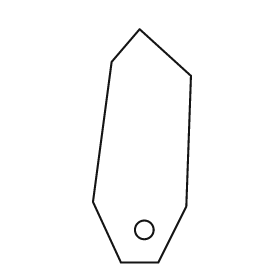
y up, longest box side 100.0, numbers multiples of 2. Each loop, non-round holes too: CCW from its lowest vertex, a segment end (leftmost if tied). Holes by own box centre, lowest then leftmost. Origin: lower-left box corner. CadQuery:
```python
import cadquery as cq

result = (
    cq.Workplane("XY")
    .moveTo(12.0, 0.0)
    .lineTo(28.0, 0.0)
    .lineTo(40.0, 24.0)
    .lineTo(42.0, 80.0)
    .lineTo(20.0, 100.0)
    .lineTo(8.0, 86.0)
    .lineTo(0.0, 26.0)
    .close()
    .moveTo(22.0, 14.0)
    .circle(4.0)
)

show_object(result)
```